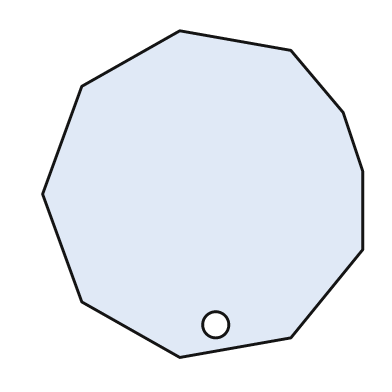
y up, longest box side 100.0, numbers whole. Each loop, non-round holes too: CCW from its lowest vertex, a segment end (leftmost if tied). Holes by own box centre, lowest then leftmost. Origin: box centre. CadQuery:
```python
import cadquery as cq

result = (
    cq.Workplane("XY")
    .moveTo(-7.0, -50.0)
    .lineTo(27.0, -44.0)
    .lineTo(49.0, -17.0)
    .lineTo(49.0, 7.0)
    .lineTo(43.0, 25.0)
    .lineTo(27.0, 44.0)
    .lineTo(-7.0, 50.0)
    .lineTo(-37.0, 33.0)
    .lineTo(-49.0, 0.0)
    .lineTo(-37.0, -33.0)
    .close()
    .moveTo(4.0, -40.0)
    .circle(4.0)
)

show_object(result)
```